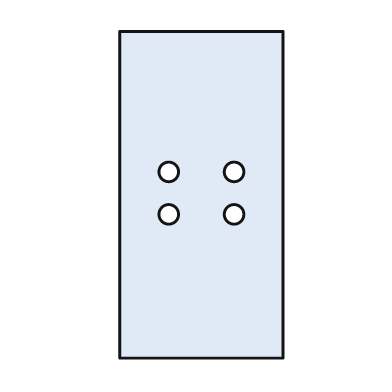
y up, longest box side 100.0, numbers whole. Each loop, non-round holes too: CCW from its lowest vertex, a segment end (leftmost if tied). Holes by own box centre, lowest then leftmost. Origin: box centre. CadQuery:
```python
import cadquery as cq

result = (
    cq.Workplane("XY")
    .moveTo(-25.0, -50.0)
    .lineTo(25.0, -50.0)
    .lineTo(25.0, 50.0)
    .lineTo(-25.0, 50.0)
    .close()
    .moveTo(-10.0, -6.0)
    .circle(3.0)
    .moveTo(10.0, -6.0)
    .circle(3.0)
    .moveTo(-10.0, 7.0)
    .circle(3.0)
    .moveTo(10.0, 7.0)
    .circle(3.0)
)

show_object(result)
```